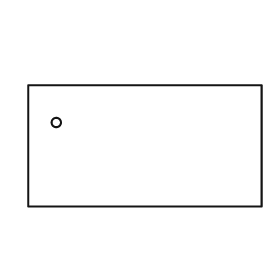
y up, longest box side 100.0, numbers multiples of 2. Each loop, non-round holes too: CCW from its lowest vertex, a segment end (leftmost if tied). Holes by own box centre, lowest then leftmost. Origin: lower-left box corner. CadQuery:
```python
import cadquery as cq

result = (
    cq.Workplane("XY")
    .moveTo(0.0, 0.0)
    .lineTo(100.0, 0.0)
    .lineTo(100.0, 52.0)
    .lineTo(0.0, 52.0)
    .close()
    .moveTo(12.0, 36.0)
    .circle(2.0)
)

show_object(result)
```